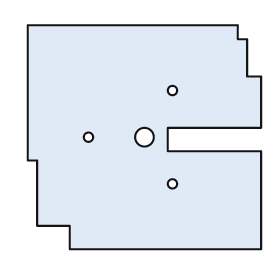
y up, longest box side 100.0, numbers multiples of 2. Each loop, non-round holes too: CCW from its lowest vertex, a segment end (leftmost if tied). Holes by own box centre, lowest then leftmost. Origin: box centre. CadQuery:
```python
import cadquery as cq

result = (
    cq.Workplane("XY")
    .moveTo(-32.0, -48.0)
    .lineTo(50.0, -48.0)
    .lineTo(50.0, -6.0)
    .lineTo(10.0, -6.0)
    .lineTo(10.0, 4.0)
    .lineTo(50.0, 4.0)
    .lineTo(50.0, 26.0)
    .lineTo(44.0, 26.0)
    .lineTo(44.0, 42.0)
    .lineTo(40.0, 42.0)
    .lineTo(40.0, 48.0)
    .lineTo(-50.0, 48.0)
    .lineTo(-50.0, -10.0)
    .lineTo(-46.0, -10.0)
    .lineTo(-46.0, -38.0)
    .lineTo(-32.0, -38.0)
    .close()
    .moveTo(12.0, -20.0)
    .circle(2.0)
    .moveTo(-24.0, 0.0)
    .circle(2.0)
    .moveTo(0.0, 0.0)
    .circle(4.0)
    .moveTo(12.0, 20.0)
    .circle(2.0)
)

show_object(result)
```